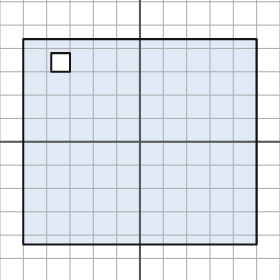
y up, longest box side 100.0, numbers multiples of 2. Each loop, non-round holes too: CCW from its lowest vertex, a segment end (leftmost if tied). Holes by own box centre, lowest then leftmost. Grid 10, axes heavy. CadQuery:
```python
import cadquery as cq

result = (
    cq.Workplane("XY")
    .moveTo(-50.0, -44.0)
    .lineTo(50.0, -44.0)
    .lineTo(50.0, 44.0)
    .lineTo(-50.0, 44.0)
    .close()
    .moveTo(-38.0, 30.0)
    .lineTo(-30.0, 30.0)
    .lineTo(-30.0, 38.0)
    .lineTo(-38.0, 38.0)
    .close()
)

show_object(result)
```